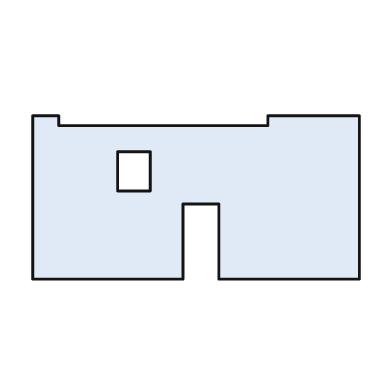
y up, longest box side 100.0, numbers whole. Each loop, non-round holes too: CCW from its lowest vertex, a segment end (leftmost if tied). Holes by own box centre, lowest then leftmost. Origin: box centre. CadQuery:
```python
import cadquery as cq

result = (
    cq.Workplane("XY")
    .moveTo(-50.0, -25.0)
    .lineTo(-4.0, -25.0)
    .lineTo(-4.0, -2.0)
    .lineTo(7.0, -2.0)
    .lineTo(7.0, -25.0)
    .lineTo(50.0, -25.0)
    .lineTo(50.0, 25.0)
    .lineTo(22.0, 25.0)
    .lineTo(22.0, 22.0)
    .lineTo(-42.0, 22.0)
    .lineTo(-42.0, 25.0)
    .lineTo(-50.0, 25.0)
    .close()
    .moveTo(-24.0, 2.0)
    .lineTo(-14.0, 2.0)
    .lineTo(-14.0, 14.0)
    .lineTo(-24.0, 14.0)
    .close()
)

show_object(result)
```